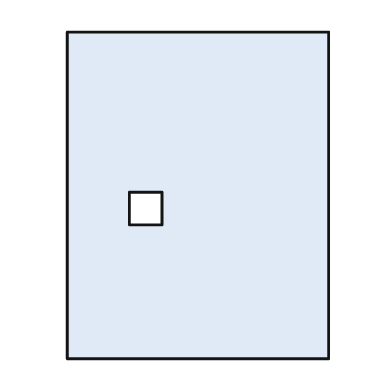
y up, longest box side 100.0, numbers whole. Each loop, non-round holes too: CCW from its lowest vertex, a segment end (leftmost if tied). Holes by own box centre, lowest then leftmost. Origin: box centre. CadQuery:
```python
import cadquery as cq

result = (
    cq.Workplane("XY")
    .moveTo(-40.0, -50.0)
    .lineTo(40.0, -50.0)
    .lineTo(40.0, 50.0)
    .lineTo(-40.0, 50.0)
    .close()
    .moveTo(-21.0, -9.0)
    .lineTo(-11.0, -9.0)
    .lineTo(-11.0, 1.0)
    .lineTo(-21.0, 1.0)
    .close()
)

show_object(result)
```